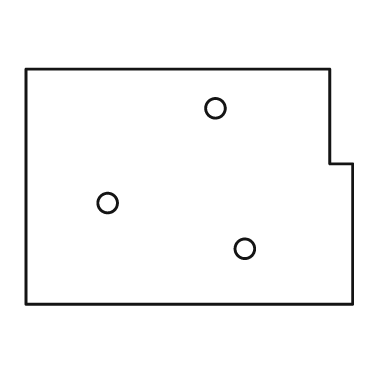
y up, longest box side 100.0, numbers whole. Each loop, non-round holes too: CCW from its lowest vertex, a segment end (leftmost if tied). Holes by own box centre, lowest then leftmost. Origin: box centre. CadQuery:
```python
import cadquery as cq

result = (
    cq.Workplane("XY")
    .moveTo(-50.0, -36.0)
    .lineTo(50.0, -36.0)
    .lineTo(50.0, 7.0)
    .lineTo(43.0, 7.0)
    .lineTo(43.0, 36.0)
    .lineTo(-50.0, 36.0)
    .close()
    .moveTo(17.0, -19.0)
    .circle(3.0)
    .moveTo(-25.0, -5.0)
    .circle(3.0)
    .moveTo(8.0, 24.0)
    .circle(3.0)
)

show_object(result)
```